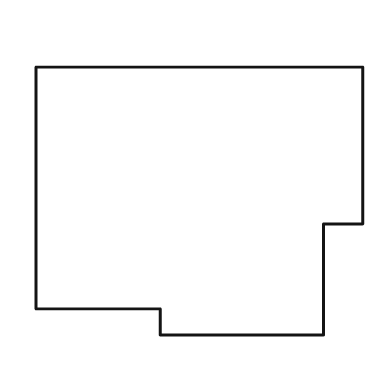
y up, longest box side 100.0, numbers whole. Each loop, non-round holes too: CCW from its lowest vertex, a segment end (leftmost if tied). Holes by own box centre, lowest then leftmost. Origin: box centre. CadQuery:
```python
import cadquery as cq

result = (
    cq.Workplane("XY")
    .moveTo(-12.0, -41.0)
    .lineTo(38.0, -41.0)
    .lineTo(38.0, -7.0)
    .lineTo(50.0, -7.0)
    .lineTo(50.0, 41.0)
    .lineTo(-50.0, 41.0)
    .lineTo(-50.0, -33.0)
    .lineTo(-12.0, -33.0)
    .close()
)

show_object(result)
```